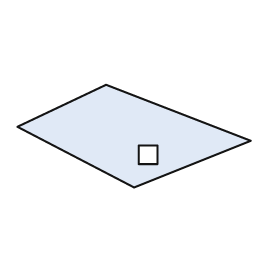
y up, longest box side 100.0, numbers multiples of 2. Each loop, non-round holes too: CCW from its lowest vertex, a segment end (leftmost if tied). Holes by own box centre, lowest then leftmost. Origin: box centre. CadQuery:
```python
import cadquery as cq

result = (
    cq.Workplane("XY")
    .moveTo(0.0, -22.0)
    .lineTo(50.0, -2.0)
    .lineTo(-12.0, 22.0)
    .lineTo(-50.0, 4.0)
    .close()
    .moveTo(2.0, -12.0)
    .lineTo(10.0, -12.0)
    .lineTo(10.0, -4.0)
    .lineTo(2.0, -4.0)
    .close()
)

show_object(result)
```